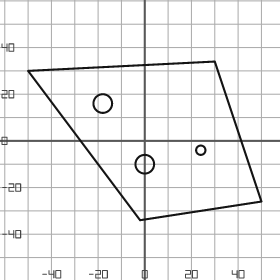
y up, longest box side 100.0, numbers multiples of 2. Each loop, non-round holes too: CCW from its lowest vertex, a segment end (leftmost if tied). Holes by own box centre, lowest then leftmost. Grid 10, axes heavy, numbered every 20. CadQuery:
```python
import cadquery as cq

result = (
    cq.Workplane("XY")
    .moveTo(-2.0, -34.0)
    .lineTo(50.0, -26.0)
    .lineTo(30.0, 34.0)
    .lineTo(-50.0, 30.0)
    .close()
    .moveTo(0.0, -10.0)
    .circle(4.0)
    .moveTo(24.0, -4.0)
    .circle(2.0)
    .moveTo(-18.0, 16.0)
    .circle(4.0)
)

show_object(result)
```